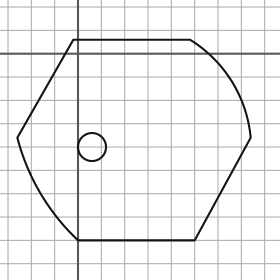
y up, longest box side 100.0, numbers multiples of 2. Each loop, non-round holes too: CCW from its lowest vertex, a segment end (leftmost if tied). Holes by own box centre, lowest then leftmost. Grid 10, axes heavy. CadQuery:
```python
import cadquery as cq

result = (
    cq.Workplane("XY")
    .moveTo(0.0, -80.0)
    .lineTo(50.0, -80.0)
    .lineTo(74.0, -36.0)
    .threePointArc((66.0, -12.0), (48.0, 6.0))
    .lineTo(-2.0, 6.0)
    .lineTo(-26.0, -36.0)
    .threePointArc((-16.0, -60.0), (0.0, -80.0))
    .close()
    .moveTo(6.0, -40.0)
    .circle(6.0)
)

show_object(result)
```